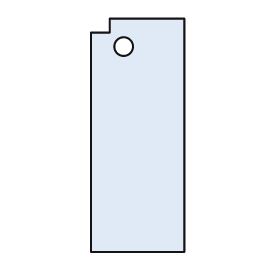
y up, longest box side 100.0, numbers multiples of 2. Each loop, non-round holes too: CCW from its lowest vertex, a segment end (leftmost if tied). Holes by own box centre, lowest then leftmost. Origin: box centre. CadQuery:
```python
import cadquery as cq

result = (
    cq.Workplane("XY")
    .moveTo(-20.0, -50.0)
    .lineTo(20.0, -50.0)
    .lineTo(20.0, 50.0)
    .lineTo(-12.0, 50.0)
    .lineTo(-12.0, 44.0)
    .lineTo(-20.0, 44.0)
    .close()
    .moveTo(-6.0, 38.0)
    .circle(4.0)
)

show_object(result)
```